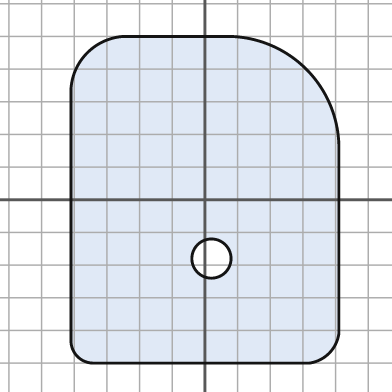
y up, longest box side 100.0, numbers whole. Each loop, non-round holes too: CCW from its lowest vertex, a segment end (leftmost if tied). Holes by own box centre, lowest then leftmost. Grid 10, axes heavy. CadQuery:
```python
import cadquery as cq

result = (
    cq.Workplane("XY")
    .moveTo(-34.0, -50.0)
    .lineTo(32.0, -50.0)
    .threePointArc((38.0, -47.0), (41.0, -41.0))
    .lineTo(41.0, 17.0)
    .threePointArc((31.0, 40.0), (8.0, 50.0))
    .lineTo(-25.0, 50.0)
    .threePointArc((-36.0, 45.0), (-41.0, 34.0))
    .lineTo(-41.0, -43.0)
    .threePointArc((-39.0, -48.0), (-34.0, -50.0))
    .close()
    .moveTo(2.0, -18.0)
    .circle(6.0)
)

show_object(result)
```